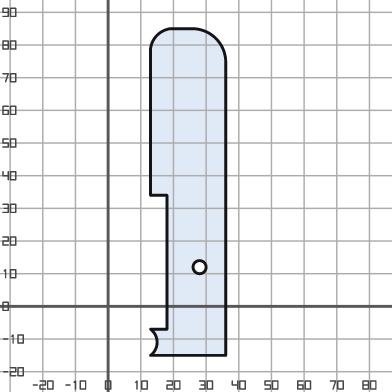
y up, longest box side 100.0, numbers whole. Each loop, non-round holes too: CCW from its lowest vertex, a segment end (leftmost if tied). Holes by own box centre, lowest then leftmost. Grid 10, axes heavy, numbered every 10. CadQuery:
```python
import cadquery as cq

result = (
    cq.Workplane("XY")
    .moveTo(13.0, -15.0)
    .lineTo(36.0, -15.0)
    .lineTo(36.0, 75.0)
    .threePointArc((33.0, 82.0), (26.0, 85.0))
    .lineTo(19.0, 85.0)
    .threePointArc((15.0, 83.0), (13.0, 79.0))
    .lineTo(13.0, 34.0)
    .lineTo(18.0, 34.0)
    .lineTo(18.0, -7.0)
    .lineTo(13.0, -7.0)
    .threePointArc((15.0, -11.0), (13.0, -15.0))
    .close()
    .moveTo(28.0, 12.0)
    .circle(2.0)
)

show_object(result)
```